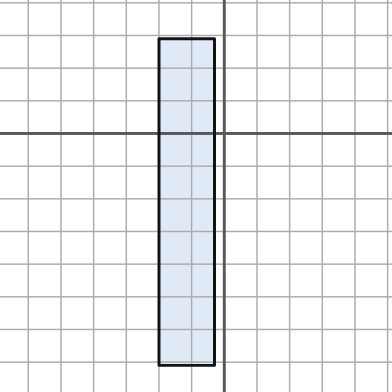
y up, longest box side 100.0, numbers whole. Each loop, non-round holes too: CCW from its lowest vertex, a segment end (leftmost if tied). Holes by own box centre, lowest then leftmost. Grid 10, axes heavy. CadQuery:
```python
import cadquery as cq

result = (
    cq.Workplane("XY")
    .moveTo(-20.0, -71.0)
    .lineTo(-3.0, -71.0)
    .lineTo(-3.0, 29.0)
    .lineTo(-20.0, 29.0)
    .close()
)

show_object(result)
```